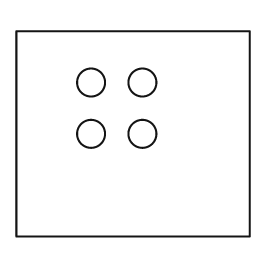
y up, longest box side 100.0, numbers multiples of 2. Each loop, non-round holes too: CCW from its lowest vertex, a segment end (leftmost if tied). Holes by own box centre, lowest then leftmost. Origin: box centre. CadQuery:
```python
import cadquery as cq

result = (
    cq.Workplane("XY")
    .moveTo(-50.0, -44.0)
    .lineTo(50.0, -44.0)
    .lineTo(50.0, 44.0)
    .lineTo(-50.0, 44.0)
    .close()
    .moveTo(-18.0, 0.0)
    .circle(6.0)
    .moveTo(4.0, 0.0)
    .circle(6.0)
    .moveTo(-18.0, 22.0)
    .circle(6.0)
    .moveTo(4.0, 22.0)
    .circle(6.0)
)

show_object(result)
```